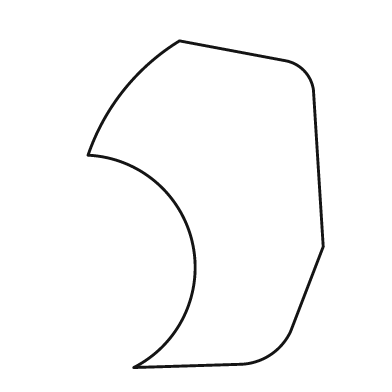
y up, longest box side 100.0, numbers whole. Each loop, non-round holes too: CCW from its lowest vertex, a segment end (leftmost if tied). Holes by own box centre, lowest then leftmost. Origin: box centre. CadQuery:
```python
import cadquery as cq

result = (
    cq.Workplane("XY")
    .moveTo(-22.0, -50.0)
    .lineTo(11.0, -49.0)
    .threePointArc((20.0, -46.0), (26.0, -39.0))
    .lineTo(36.0, -13.0)
    .lineTo(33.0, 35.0)
    .threePointArc((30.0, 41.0), (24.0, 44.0))
    .lineTo(-8.0, 50.0)
    .threePointArc((-25.0, 35.0), (-36.0, 15.0))
    .threePointArc((-4.0, -12.0), (-22.0, -50.0))
    .close()
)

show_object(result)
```